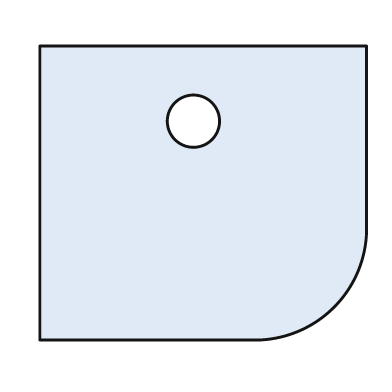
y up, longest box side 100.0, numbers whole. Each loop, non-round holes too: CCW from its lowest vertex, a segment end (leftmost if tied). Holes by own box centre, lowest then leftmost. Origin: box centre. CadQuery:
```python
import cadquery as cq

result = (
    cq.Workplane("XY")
    .moveTo(-50.0, -45.0)
    .lineTo(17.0, -45.0)
    .threePointArc((40.0, -35.0), (50.0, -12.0))
    .lineTo(50.0, 45.0)
    .lineTo(-50.0, 45.0)
    .close()
    .moveTo(-3.0, 22.0)
    .circle(8.0)
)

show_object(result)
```